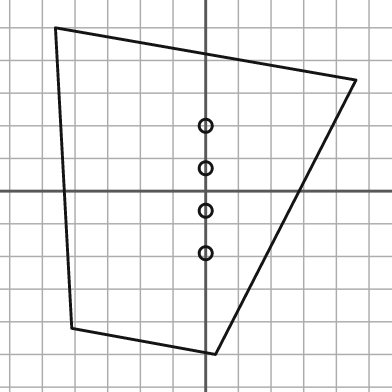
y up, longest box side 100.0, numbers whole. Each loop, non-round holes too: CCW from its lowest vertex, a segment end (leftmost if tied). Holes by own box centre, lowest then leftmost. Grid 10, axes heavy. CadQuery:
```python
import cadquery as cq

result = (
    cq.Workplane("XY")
    .moveTo(3.0, -50.0)
    .lineTo(46.0, 34.0)
    .lineTo(-46.0, 50.0)
    .lineTo(-41.0, -42.0)
    .close()
    .moveTo(0.0, -19.0)
    .circle(2.0)
    .moveTo(0.0, -6.0)
    .circle(2.0)
    .moveTo(0.0, 7.0)
    .circle(2.0)
    .moveTo(0.0, 20.0)
    .circle(2.0)
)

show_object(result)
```